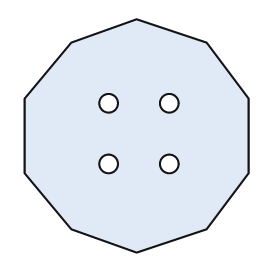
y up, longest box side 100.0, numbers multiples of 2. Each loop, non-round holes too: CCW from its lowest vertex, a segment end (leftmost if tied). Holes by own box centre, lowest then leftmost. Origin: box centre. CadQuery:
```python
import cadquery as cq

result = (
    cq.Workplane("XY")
    .moveTo(0.0, -50.0)
    .lineTo(30.0, -40.0)
    .lineTo(48.0, -16.0)
    .lineTo(48.0, 16.0)
    .lineTo(30.0, 40.0)
    .lineTo(0.0, 50.0)
    .lineTo(-28.0, 40.0)
    .lineTo(-48.0, 16.0)
    .lineTo(-48.0, -16.0)
    .lineTo(-28.0, -40.0)
    .close()
    .moveTo(-12.0, -12.0)
    .circle(4.0)
    .moveTo(14.0, -12.0)
    .circle(4.0)
    .moveTo(-12.0, 14.0)
    .circle(4.0)
    .moveTo(14.0, 14.0)
    .circle(4.0)
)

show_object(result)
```